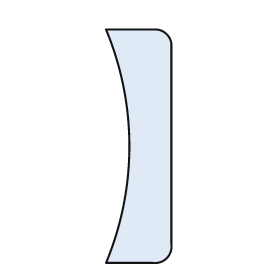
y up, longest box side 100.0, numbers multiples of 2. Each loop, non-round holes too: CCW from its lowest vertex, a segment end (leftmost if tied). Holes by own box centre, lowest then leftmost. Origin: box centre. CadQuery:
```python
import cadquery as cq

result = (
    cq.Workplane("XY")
    .moveTo(-14.0, -50.0)
    .lineTo(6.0, -50.0)
    .threePointArc((12.0, -48.0), (14.0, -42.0))
    .lineTo(14.0, 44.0)
    .threePointArc((12.0, 48.0), (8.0, 50.0))
    .lineTo(-14.0, 50.0)
    .threePointArc((-4.0, 0.0), (-14.0, -50.0))
    .close()
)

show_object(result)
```